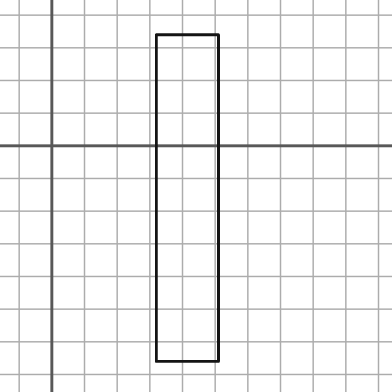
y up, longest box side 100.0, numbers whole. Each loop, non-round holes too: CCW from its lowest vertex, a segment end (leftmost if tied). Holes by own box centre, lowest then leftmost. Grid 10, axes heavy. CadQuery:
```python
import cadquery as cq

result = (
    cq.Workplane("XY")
    .moveTo(32.0, -66.0)
    .lineTo(51.0, -66.0)
    .lineTo(51.0, 34.0)
    .lineTo(32.0, 34.0)
    .close()
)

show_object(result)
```